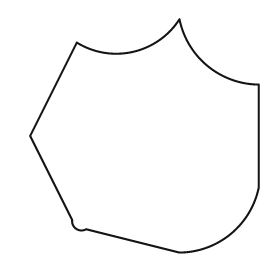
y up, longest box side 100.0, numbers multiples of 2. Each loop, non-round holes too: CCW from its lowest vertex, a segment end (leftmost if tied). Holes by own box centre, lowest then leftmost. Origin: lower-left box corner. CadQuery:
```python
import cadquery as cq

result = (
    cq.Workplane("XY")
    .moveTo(64.0, 0.0)
    .threePointArc((86.0, 8.0), (98.0, 28.0))
    .lineTo(98.0, 72.0)
    .threePointArc((76.0, 80.0), (64.0, 100.0))
    .threePointArc((44.0, 86.0), (20.0, 90.0))
    .lineTo(0.0, 50.0)
    .lineTo(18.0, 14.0)
    .threePointArc((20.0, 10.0), (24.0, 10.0))
    .close()
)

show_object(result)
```